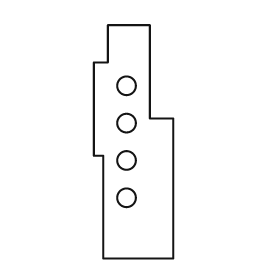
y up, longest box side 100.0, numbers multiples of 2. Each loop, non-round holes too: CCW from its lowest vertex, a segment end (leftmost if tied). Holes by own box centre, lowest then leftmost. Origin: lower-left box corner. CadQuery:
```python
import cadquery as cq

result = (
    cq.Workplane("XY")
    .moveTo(4.0, 0.0)
    .lineTo(34.0, 0.0)
    .lineTo(34.0, 60.0)
    .lineTo(24.0, 60.0)
    .lineTo(24.0, 100.0)
    .lineTo(6.0, 100.0)
    .lineTo(6.0, 84.0)
    .lineTo(0.0, 84.0)
    .lineTo(0.0, 44.0)
    .lineTo(4.0, 44.0)
    .close()
    .moveTo(14.0, 26.0)
    .circle(4.0)
    .moveTo(14.0, 42.0)
    .circle(4.0)
    .moveTo(14.0, 58.0)
    .circle(4.0)
    .moveTo(14.0, 74.0)
    .circle(4.0)
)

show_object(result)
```